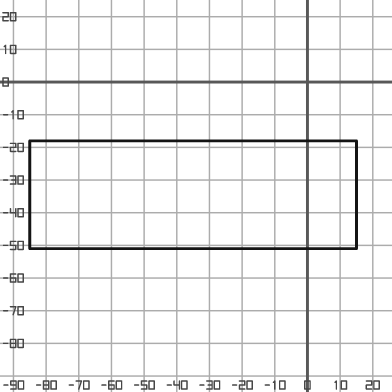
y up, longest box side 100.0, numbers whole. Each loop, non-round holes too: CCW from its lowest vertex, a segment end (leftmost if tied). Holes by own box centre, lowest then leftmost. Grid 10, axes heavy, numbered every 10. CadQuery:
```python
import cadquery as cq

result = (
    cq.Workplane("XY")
    .moveTo(-85.0, -51.0)
    .lineTo(15.0, -51.0)
    .lineTo(15.0, -18.0)
    .lineTo(-85.0, -18.0)
    .close()
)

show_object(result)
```